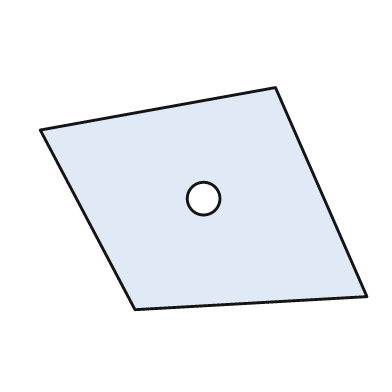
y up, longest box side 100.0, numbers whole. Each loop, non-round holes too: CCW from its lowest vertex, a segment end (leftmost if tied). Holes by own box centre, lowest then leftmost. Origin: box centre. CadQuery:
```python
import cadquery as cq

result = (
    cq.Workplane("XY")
    .moveTo(-21.0, -34.0)
    .lineTo(50.0, -30.0)
    .lineTo(22.0, 34.0)
    .lineTo(-50.0, 21.0)
    .close()
    .moveTo(0.0, 0.0)
    .circle(5.0)
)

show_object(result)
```